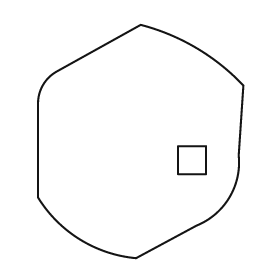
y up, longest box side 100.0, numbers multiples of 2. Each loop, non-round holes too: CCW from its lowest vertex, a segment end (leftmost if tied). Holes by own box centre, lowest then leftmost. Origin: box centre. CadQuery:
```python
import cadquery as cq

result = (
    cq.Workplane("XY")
    .moveTo(-2.0, -50.0)
    .lineTo(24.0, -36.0)
    .threePointArc((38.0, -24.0), (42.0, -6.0))
    .lineTo(44.0, 24.0)
    .threePointArc((24.0, 40.0), (0.0, 50.0))
    .lineTo(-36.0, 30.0)
    .threePointArc((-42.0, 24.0), (-44.0, 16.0))
    .lineTo(-44.0, -24.0)
    .threePointArc((-26.0, -42.0), (-2.0, -50.0))
    .close()
    .moveTo(16.0, -14.0)
    .lineTo(28.0, -14.0)
    .lineTo(28.0, -2.0)
    .lineTo(16.0, -2.0)
    .close()
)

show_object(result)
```